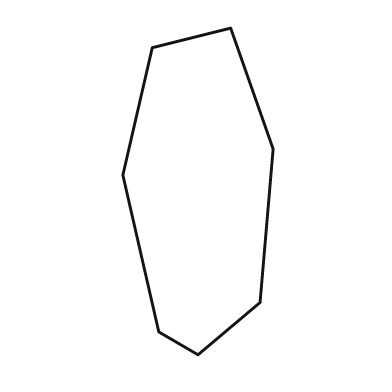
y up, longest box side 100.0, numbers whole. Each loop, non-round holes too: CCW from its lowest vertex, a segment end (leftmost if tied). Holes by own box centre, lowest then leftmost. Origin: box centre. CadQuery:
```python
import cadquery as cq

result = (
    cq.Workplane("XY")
    .moveTo(0.0, -50.0)
    .lineTo(19.0, -34.0)
    .lineTo(23.0, 13.0)
    .lineTo(10.0, 50.0)
    .lineTo(-14.0, 44.0)
    .lineTo(-23.0, 5.0)
    .lineTo(-12.0, -43.0)
    .close()
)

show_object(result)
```